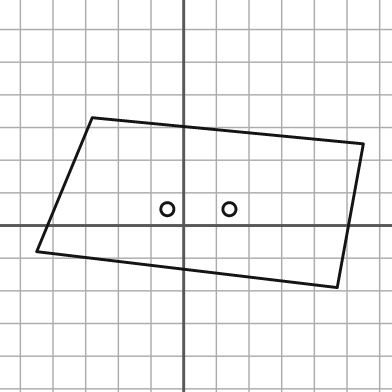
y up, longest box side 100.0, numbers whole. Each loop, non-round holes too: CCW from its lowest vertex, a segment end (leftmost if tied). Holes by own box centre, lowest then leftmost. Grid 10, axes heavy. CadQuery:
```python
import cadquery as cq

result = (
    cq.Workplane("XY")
    .moveTo(47.0, -19.0)
    .lineTo(55.0, 25.0)
    .lineTo(-28.0, 33.0)
    .lineTo(-45.0, -8.0)
    .close()
    .moveTo(-5.0, 5.0)
    .circle(2.0)
    .moveTo(14.0, 5.0)
    .circle(2.0)
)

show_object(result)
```